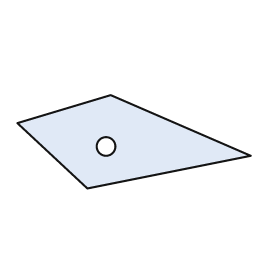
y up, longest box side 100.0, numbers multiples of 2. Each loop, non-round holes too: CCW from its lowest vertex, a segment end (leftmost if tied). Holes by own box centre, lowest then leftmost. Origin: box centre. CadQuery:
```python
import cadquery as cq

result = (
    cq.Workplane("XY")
    .moveTo(-20.0, -20.0)
    .lineTo(50.0, -6.0)
    .lineTo(-10.0, 20.0)
    .lineTo(-50.0, 8.0)
    .close()
    .moveTo(-12.0, -2.0)
    .circle(4.0)
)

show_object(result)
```